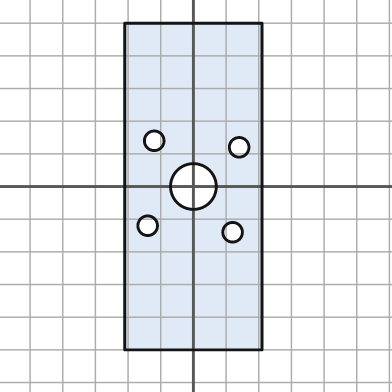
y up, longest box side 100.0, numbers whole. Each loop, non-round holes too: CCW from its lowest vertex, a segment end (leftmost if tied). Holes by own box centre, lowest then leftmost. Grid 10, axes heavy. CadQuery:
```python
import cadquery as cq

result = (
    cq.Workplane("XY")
    .moveTo(-21.0, -50.0)
    .lineTo(21.0, -50.0)
    .lineTo(21.0, 50.0)
    .lineTo(-21.0, 50.0)
    .close()
    .moveTo(12.0, -14.0)
    .circle(3.0)
    .moveTo(-14.0, -12.0)
    .circle(3.0)
    .moveTo(0.0, 0.0)
    .circle(7.0)
    .moveTo(14.0, 12.0)
    .circle(3.0)
    .moveTo(-12.0, 14.0)
    .circle(3.0)
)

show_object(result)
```